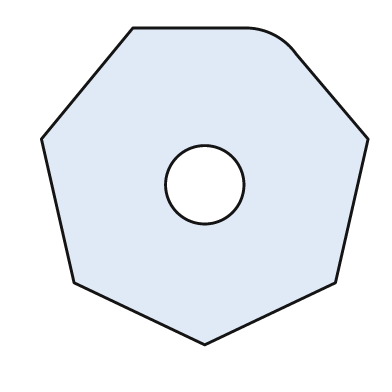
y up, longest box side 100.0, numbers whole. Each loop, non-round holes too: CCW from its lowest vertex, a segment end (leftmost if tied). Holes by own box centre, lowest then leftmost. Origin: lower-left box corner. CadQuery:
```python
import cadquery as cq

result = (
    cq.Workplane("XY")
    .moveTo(50.0, 0.0)
    .lineTo(90.0, 19.0)
    .lineTo(100.0, 63.0)
    .lineTo(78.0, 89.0)
    .threePointArc((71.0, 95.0), (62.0, 97.0))
    .lineTo(28.0, 97.0)
    .lineTo(0.0, 63.0)
    .lineTo(10.0, 19.0)
    .close()
    .moveTo(50.0, 49.0)
    .circle(12.0)
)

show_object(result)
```